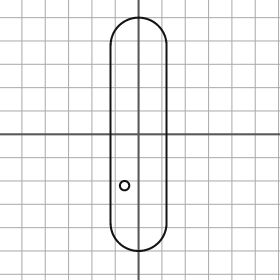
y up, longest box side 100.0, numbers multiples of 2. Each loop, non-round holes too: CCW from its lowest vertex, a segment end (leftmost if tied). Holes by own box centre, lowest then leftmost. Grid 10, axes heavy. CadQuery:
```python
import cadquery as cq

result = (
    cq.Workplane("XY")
    .moveTo(-12.0, -38.0)
    .threePointArc((0.0, -50.0), (12.0, -38.0))
    .lineTo(12.0, 38.0)
    .threePointArc((0.0, 50.0), (-12.0, 38.0))
    .close()
    .moveTo(-6.0, -22.0)
    .circle(2.0)
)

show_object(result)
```